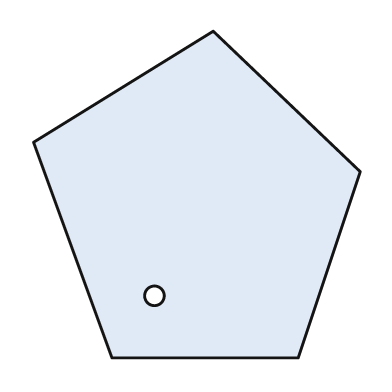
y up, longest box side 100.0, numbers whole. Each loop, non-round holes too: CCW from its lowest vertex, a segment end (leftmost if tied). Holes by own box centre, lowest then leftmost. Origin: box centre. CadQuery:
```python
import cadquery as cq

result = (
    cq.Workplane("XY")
    .moveTo(-26.0, -50.0)
    .lineTo(31.0, -50.0)
    .lineTo(50.0, 7.0)
    .lineTo(5.0, 50.0)
    .lineTo(-50.0, 16.0)
    .close()
    .moveTo(-13.0, -31.0)
    .circle(3.0)
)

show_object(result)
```